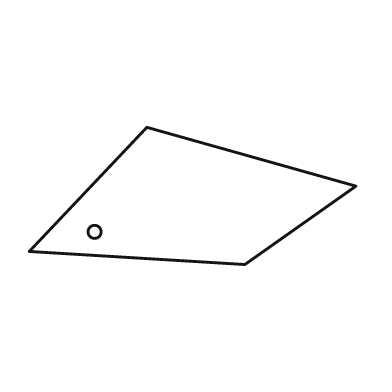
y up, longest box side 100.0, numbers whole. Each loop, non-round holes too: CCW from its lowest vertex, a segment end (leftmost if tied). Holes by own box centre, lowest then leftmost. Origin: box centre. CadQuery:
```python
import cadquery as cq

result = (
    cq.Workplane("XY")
    .moveTo(16.0, -21.0)
    .lineTo(50.0, 3.0)
    .lineTo(-14.0, 21.0)
    .lineTo(-50.0, -17.0)
    .close()
    .moveTo(-30.0, -11.0)
    .circle(2.0)
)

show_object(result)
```